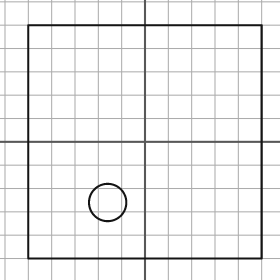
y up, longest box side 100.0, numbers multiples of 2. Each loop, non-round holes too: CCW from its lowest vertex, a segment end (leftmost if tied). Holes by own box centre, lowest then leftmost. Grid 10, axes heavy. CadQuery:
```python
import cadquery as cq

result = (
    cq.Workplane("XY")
    .moveTo(-50.0, -50.0)
    .lineTo(50.0, -50.0)
    .lineTo(50.0, 50.0)
    .lineTo(-50.0, 50.0)
    .close()
    .moveTo(-16.0, -26.0)
    .circle(8.0)
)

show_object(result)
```